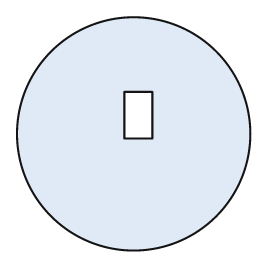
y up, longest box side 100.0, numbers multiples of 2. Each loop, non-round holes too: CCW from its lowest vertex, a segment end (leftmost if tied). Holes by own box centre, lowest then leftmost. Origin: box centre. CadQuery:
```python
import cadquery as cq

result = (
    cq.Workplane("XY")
    .moveTo(0.0, 0.0)
    .circle(50.0)
    .moveTo(-4.0, -2.0)
    .lineTo(8.0, -2.0)
    .lineTo(8.0, 18.0)
    .lineTo(-4.0, 18.0)
    .close()
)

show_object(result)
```